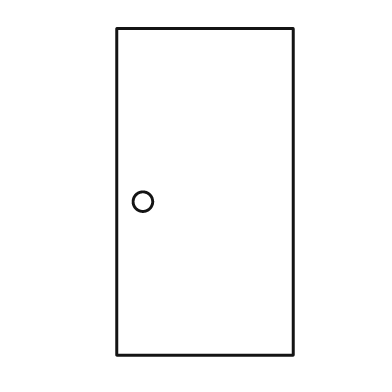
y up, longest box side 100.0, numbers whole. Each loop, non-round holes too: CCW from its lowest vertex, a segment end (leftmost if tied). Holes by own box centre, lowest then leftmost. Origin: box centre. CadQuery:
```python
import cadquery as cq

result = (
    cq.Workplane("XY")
    .moveTo(-27.0, -50.0)
    .lineTo(27.0, -50.0)
    .lineTo(27.0, 50.0)
    .lineTo(-27.0, 50.0)
    .close()
    .moveTo(-19.0, -3.0)
    .circle(3.0)
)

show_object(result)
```